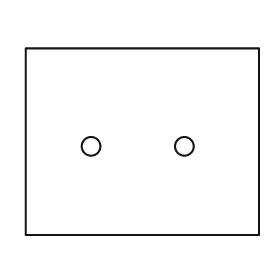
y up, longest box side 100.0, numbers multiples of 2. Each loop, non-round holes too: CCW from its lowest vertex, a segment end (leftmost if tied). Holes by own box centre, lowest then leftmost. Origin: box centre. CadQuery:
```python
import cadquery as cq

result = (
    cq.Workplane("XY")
    .moveTo(-50.0, -40.0)
    .lineTo(50.0, -40.0)
    .lineTo(50.0, 40.0)
    .lineTo(-50.0, 40.0)
    .close()
    .moveTo(-22.0, -2.0)
    .circle(4.0)
    .moveTo(18.0, -2.0)
    .circle(4.0)
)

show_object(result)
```